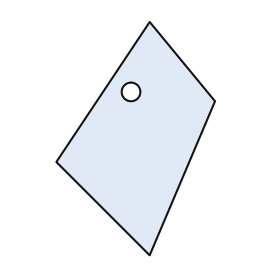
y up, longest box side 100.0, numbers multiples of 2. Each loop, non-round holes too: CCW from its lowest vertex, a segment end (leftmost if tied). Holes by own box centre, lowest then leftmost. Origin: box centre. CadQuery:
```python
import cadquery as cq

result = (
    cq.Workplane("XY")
    .moveTo(6.0, -50.0)
    .lineTo(34.0, 16.0)
    .lineTo(6.0, 50.0)
    .lineTo(-34.0, -10.0)
    .close()
    .moveTo(-2.0, 20.0)
    .circle(4.0)
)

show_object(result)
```